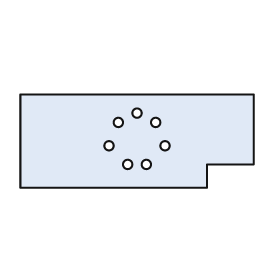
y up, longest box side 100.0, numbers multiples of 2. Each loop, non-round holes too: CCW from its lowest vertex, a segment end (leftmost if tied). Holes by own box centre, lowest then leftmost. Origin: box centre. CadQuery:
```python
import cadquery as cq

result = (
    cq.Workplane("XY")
    .moveTo(-50.0, -20.0)
    .lineTo(30.0, -20.0)
    .lineTo(30.0, -10.0)
    .lineTo(50.0, -10.0)
    .lineTo(50.0, 20.0)
    .lineTo(-50.0, 20.0)
    .close()
    .moveTo(-4.0, -10.0)
    .circle(2.0)
    .moveTo(4.0, -10.0)
    .circle(2.0)
    .moveTo(-12.0, -2.0)
    .circle(2.0)
    .moveTo(12.0, -2.0)
    .circle(2.0)
    .moveTo(-8.0, 8.0)
    .circle(2.0)
    .moveTo(8.0, 8.0)
    .circle(2.0)
    .moveTo(0.0, 12.0)
    .circle(2.0)
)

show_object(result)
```